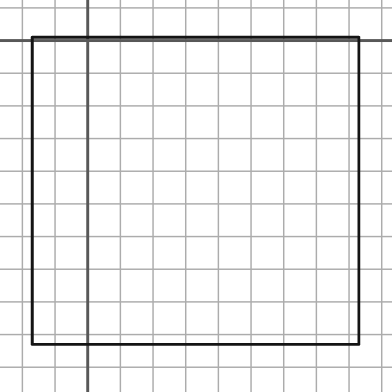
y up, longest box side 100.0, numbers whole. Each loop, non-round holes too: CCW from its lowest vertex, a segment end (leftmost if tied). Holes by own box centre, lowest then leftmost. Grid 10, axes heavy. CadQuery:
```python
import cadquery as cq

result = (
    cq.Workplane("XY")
    .moveTo(-17.0, -93.0)
    .lineTo(83.0, -93.0)
    .lineTo(83.0, 1.0)
    .lineTo(-17.0, 1.0)
    .close()
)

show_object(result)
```